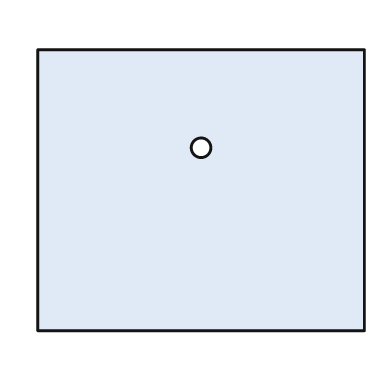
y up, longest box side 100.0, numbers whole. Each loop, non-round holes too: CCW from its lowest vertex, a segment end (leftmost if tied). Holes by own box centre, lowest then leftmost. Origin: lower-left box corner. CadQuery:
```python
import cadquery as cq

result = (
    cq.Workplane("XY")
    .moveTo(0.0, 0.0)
    .lineTo(100.0, 0.0)
    .lineTo(100.0, 86.0)
    .lineTo(0.0, 86.0)
    .close()
    .moveTo(50.0, 56.0)
    .circle(3.0)
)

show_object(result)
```